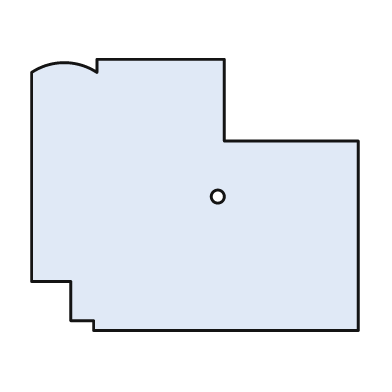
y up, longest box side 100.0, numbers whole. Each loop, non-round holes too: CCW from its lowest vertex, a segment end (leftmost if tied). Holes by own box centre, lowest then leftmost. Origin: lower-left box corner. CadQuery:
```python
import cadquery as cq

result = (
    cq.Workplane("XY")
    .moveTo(19.0, 0.0)
    .lineTo(100.0, 0.0)
    .lineTo(100.0, 58.0)
    .lineTo(59.0, 58.0)
    .lineTo(59.0, 83.0)
    .lineTo(20.0, 83.0)
    .lineTo(20.0, 79.0)
    .threePointArc((10.0, 82.0), (0.0, 79.0))
    .lineTo(0.0, 15.0)
    .lineTo(12.0, 15.0)
    .lineTo(12.0, 3.0)
    .lineTo(19.0, 3.0)
    .close()
    .moveTo(57.0, 41.0)
    .circle(2.0)
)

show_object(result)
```